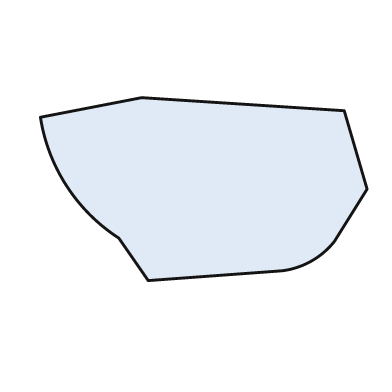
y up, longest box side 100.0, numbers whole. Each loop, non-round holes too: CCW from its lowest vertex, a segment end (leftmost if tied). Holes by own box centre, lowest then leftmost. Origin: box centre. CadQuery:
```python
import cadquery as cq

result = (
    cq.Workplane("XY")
    .moveTo(-17.0, -28.0)
    .lineTo(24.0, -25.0)
    .threePointArc((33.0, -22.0), (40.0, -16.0))
    .lineTo(50.0, 0.0)
    .lineTo(43.0, 24.0)
    .lineTo(-19.0, 28.0)
    .lineTo(-50.0, 22.0)
    .threePointArc((-42.0, 1.0), (-26.0, -15.0))
    .close()
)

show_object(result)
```